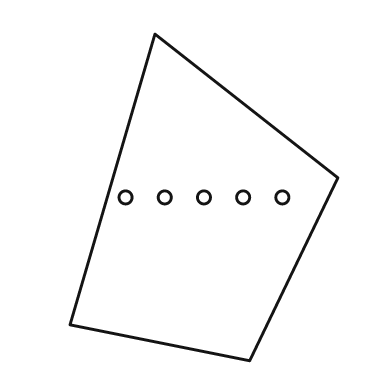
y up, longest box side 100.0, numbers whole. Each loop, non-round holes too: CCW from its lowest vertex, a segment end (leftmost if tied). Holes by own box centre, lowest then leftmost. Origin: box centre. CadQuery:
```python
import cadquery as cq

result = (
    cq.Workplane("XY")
    .moveTo(14.0, -50.0)
    .lineTo(41.0, 6.0)
    .lineTo(-15.0, 50.0)
    .lineTo(-41.0, -39.0)
    .close()
    .moveTo(-24.0, 0.0)
    .circle(2.0)
    .moveTo(-12.0, 0.0)
    .circle(2.0)
    .moveTo(0.0, 0.0)
    .circle(2.0)
    .moveTo(12.0, 0.0)
    .circle(2.0)
    .moveTo(24.0, 0.0)
    .circle(2.0)
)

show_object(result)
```